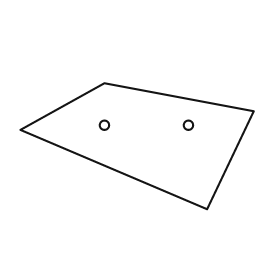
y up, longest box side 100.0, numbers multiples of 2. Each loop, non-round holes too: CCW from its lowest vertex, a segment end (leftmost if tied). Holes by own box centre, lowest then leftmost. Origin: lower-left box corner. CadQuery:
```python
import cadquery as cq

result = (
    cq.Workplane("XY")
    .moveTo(80.0, 0.0)
    .lineTo(100.0, 42.0)
    .lineTo(36.0, 54.0)
    .lineTo(0.0, 34.0)
    .close()
    .moveTo(36.0, 36.0)
    .circle(2.0)
    .moveTo(72.0, 36.0)
    .circle(2.0)
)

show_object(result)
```